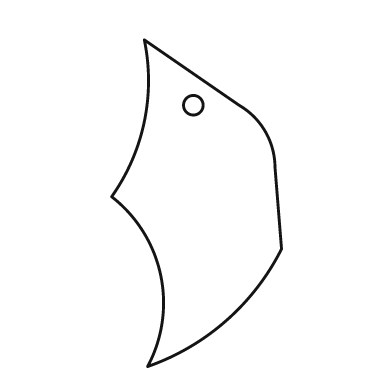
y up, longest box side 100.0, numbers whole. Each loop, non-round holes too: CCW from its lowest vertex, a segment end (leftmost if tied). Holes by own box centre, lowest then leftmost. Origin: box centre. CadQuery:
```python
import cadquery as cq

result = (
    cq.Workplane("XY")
    .moveTo(-15.0, -50.0)
    .threePointArc((9.0, -36.0), (26.0, -14.0))
    .lineTo(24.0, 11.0)
    .threePointArc((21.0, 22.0), (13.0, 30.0))
    .lineTo(-16.0, 50.0)
    .threePointArc((-16.0, 25.0), (-26.0, 2.0))
    .threePointArc((-11.0, -22.0), (-15.0, -50.0))
    .close()
    .moveTo(-1.0, 30.0)
    .circle(3.0)
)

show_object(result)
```